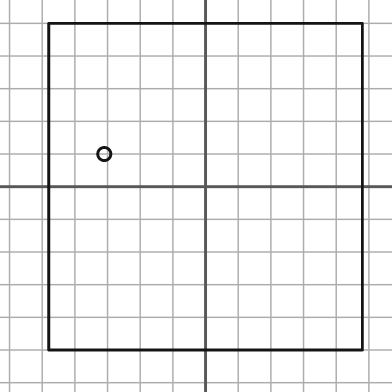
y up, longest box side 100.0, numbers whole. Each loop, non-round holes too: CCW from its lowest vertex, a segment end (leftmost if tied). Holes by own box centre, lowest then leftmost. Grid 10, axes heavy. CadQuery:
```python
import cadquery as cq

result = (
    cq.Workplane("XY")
    .moveTo(-48.0, -50.0)
    .lineTo(48.0, -50.0)
    .lineTo(48.0, 50.0)
    .lineTo(-48.0, 50.0)
    .close()
    .moveTo(-31.0, 10.0)
    .circle(2.0)
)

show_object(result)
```